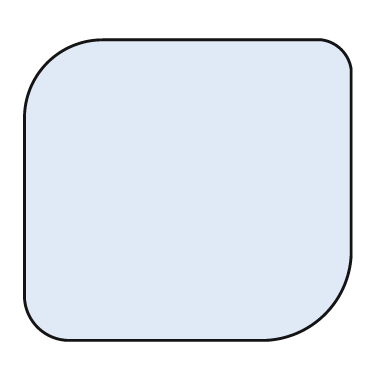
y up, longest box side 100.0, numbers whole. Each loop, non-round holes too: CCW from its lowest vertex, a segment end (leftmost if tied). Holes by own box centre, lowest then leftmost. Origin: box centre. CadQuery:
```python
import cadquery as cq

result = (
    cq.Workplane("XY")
    .moveTo(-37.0, -46.0)
    .lineTo(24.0, -46.0)
    .threePointArc((42.0, -38.0), (50.0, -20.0))
    .lineTo(50.0, 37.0)
    .threePointArc((47.0, 43.0), (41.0, 46.0))
    .lineTo(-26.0, 46.0)
    .threePointArc((-43.0, 39.0), (-50.0, 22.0))
    .lineTo(-50.0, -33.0)
    .threePointArc((-46.0, -42.0), (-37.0, -46.0))
    .close()
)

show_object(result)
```